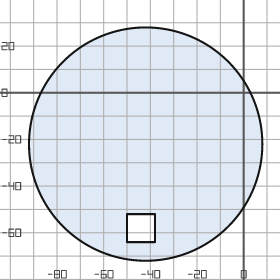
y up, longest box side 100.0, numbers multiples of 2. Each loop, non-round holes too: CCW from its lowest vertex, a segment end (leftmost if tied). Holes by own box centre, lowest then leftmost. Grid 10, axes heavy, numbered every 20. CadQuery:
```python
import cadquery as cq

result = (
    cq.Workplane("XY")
    .moveTo(-42.0, -22.0)
    .circle(50.0)
    .moveTo(-50.0, -64.0)
    .lineTo(-38.0, -64.0)
    .lineTo(-38.0, -52.0)
    .lineTo(-50.0, -52.0)
    .close()
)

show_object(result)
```